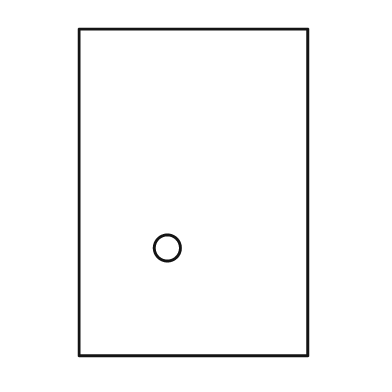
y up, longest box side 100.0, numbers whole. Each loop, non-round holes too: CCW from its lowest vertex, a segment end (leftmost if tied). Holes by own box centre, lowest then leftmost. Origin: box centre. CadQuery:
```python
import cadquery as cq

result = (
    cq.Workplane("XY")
    .moveTo(-35.0, -50.0)
    .lineTo(35.0, -50.0)
    .lineTo(35.0, 50.0)
    .lineTo(-35.0, 50.0)
    .close()
    .moveTo(-8.0, -17.0)
    .circle(4.0)
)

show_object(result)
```